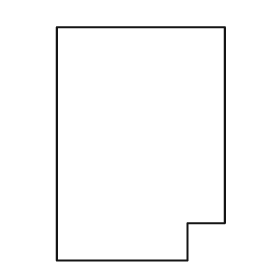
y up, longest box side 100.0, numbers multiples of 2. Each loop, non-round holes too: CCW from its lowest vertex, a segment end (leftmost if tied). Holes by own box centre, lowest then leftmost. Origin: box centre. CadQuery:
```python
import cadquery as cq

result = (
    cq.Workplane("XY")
    .moveTo(-36.0, -50.0)
    .lineTo(20.0, -50.0)
    .lineTo(20.0, -34.0)
    .lineTo(36.0, -34.0)
    .lineTo(36.0, 50.0)
    .lineTo(-36.0, 50.0)
    .close()
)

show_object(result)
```